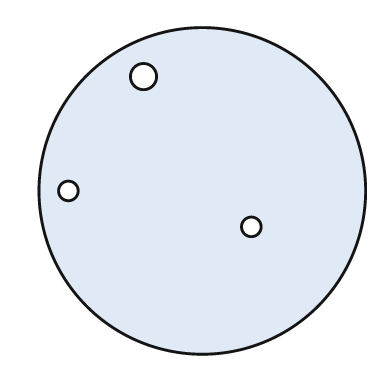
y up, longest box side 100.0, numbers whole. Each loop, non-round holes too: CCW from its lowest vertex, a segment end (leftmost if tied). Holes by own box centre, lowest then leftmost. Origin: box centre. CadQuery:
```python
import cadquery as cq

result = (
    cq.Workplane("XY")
    .moveTo(0.0, 0.0)
    .circle(50.0)
    .moveTo(15.0, -11.0)
    .circle(3.0)
    .moveTo(-41.0, 0.0)
    .circle(3.0)
    .moveTo(-18.0, 35.0)
    .circle(4.0)
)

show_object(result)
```